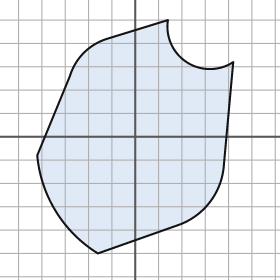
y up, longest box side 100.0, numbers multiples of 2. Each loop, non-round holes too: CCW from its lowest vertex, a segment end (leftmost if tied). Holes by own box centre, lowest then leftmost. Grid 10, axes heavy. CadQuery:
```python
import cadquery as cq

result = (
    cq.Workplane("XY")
    .moveTo(-16.0, -50.0)
    .lineTo(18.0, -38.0)
    .threePointArc((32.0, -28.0), (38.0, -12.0))
    .lineTo(42.0, 32.0)
    .threePointArc((22.0, 32.0), (14.0, 50.0))
    .lineTo(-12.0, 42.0)
    .threePointArc((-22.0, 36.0), (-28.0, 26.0))
    .lineTo(-42.0, -8.0)
    .threePointArc((-34.0, -32.0), (-16.0, -50.0))
    .close()
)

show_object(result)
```